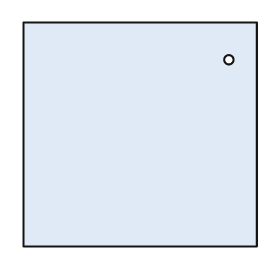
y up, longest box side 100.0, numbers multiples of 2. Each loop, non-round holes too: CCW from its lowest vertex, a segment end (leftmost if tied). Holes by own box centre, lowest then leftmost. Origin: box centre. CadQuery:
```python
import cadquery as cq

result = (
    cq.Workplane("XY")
    .moveTo(-50.0, -48.0)
    .lineTo(50.0, -48.0)
    .lineTo(50.0, 48.0)
    .lineTo(-50.0, 48.0)
    .close()
    .moveTo(38.0, 32.0)
    .circle(2.0)
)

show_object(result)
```